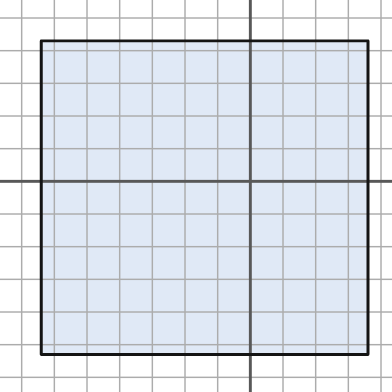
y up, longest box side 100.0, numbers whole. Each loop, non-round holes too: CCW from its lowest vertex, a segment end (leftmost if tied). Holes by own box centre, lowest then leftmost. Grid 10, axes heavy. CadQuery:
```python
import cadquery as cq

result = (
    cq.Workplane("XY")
    .moveTo(-64.0, -53.0)
    .lineTo(36.0, -53.0)
    .lineTo(36.0, 43.0)
    .lineTo(-64.0, 43.0)
    .close()
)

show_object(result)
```